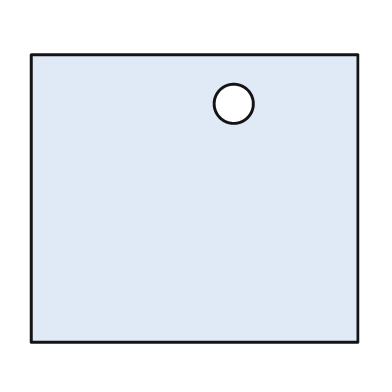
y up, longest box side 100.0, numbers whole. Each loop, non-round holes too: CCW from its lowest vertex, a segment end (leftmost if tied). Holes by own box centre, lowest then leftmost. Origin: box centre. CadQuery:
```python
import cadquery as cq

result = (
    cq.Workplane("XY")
    .moveTo(-50.0, -44.0)
    .lineTo(50.0, -44.0)
    .lineTo(50.0, 44.0)
    .lineTo(-50.0, 44.0)
    .close()
    .moveTo(12.0, 29.0)
    .circle(6.0)
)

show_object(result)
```